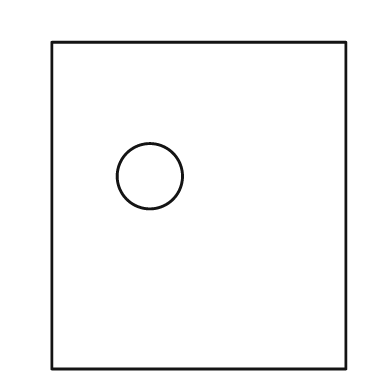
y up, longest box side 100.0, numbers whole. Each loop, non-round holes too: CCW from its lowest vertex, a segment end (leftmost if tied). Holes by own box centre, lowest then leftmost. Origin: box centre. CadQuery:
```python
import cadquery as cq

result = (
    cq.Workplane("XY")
    .moveTo(-45.0, -50.0)
    .lineTo(45.0, -50.0)
    .lineTo(45.0, 50.0)
    .lineTo(-45.0, 50.0)
    .close()
    .moveTo(-15.0, 9.0)
    .circle(10.0)
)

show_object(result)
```